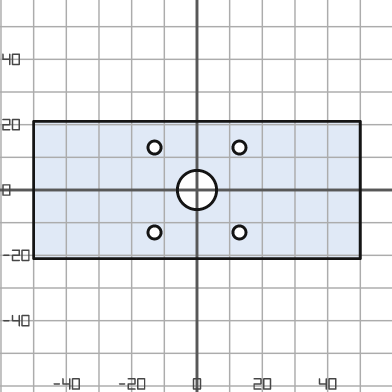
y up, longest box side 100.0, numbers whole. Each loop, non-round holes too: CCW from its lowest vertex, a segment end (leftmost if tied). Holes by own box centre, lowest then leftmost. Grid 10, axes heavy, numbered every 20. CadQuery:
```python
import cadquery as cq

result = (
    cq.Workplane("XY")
    .moveTo(-50.0, -21.0)
    .lineTo(50.0, -21.0)
    .lineTo(50.0, 21.0)
    .lineTo(-50.0, 21.0)
    .close()
    .moveTo(-13.0, -13.0)
    .circle(2.0)
    .moveTo(13.0, -13.0)
    .circle(2.0)
    .moveTo(0.0, 0.0)
    .circle(6.0)
    .moveTo(-13.0, 13.0)
    .circle(2.0)
    .moveTo(13.0, 13.0)
    .circle(2.0)
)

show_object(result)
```